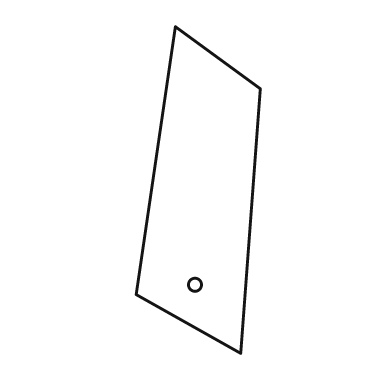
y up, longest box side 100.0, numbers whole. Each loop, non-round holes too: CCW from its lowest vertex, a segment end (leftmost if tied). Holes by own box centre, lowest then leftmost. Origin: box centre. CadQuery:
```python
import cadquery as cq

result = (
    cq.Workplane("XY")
    .moveTo(13.0, -50.0)
    .lineTo(19.0, 31.0)
    .lineTo(-7.0, 50.0)
    .lineTo(-19.0, -32.0)
    .close()
    .moveTo(-1.0, -29.0)
    .circle(2.0)
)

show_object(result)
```